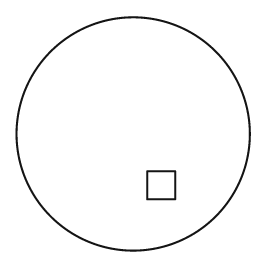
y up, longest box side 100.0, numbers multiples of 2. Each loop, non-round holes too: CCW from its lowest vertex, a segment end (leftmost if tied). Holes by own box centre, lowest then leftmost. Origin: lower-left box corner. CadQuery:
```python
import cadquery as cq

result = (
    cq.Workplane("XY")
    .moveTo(50.0, 50.0)
    .circle(50.0)
    .moveTo(56.0, 22.0)
    .lineTo(68.0, 22.0)
    .lineTo(68.0, 34.0)
    .lineTo(56.0, 34.0)
    .close()
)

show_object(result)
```